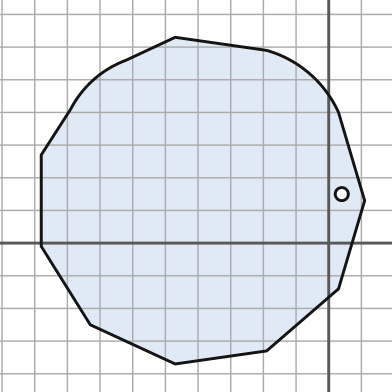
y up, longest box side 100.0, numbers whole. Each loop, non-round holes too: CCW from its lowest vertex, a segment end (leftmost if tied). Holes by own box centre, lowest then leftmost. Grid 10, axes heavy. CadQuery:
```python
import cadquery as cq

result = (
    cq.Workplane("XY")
    .moveTo(-47.0, -37.0)
    .lineTo(-19.0, -33.0)
    .lineTo(3.0, -14.0)
    .lineTo(11.0, 13.0)
    .lineTo(3.0, 40.0)
    .threePointArc((-6.0, 52.0), (-19.0, 59.0))
    .lineTo(-47.0, 63.0)
    .lineTo(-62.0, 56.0)
    .threePointArc((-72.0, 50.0), (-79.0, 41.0))
    .lineTo(-88.0, 27.0)
    .lineTo(-88.0, -1.0)
    .lineTo(-73.0, -25.0)
    .close()
    .moveTo(4.0, 15.0)
    .circle(2.0)
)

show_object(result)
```